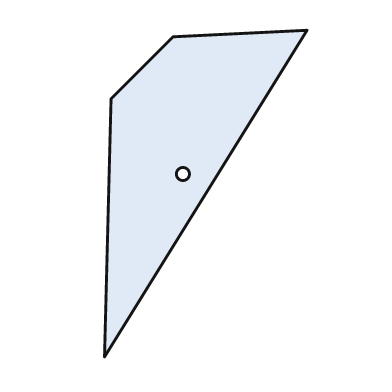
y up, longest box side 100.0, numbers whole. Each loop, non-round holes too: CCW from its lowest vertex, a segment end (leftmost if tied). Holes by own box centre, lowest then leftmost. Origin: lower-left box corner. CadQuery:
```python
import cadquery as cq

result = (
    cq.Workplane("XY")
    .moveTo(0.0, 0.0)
    .lineTo(62.0, 100.0)
    .lineTo(21.0, 98.0)
    .lineTo(2.0, 79.0)
    .close()
    .moveTo(24.0, 56.0)
    .circle(2.0)
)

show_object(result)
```